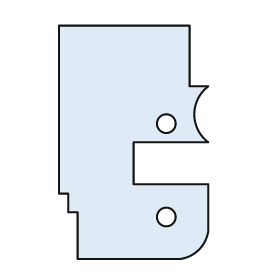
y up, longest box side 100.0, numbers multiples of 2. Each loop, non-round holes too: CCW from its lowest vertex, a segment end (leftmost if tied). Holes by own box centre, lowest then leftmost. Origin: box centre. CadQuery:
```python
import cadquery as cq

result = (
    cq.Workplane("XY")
    .moveTo(-24.0, -50.0)
    .lineTo(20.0, -50.0)
    .threePointArc((28.0, -46.0), (32.0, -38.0))
    .lineTo(32.0, -18.0)
    .lineTo(0.0, -18.0)
    .lineTo(0.0, 0.0)
    .lineTo(32.0, 0.0)
    .threePointArc((26.0, 12.0), (32.0, 24.0))
    .lineTo(24.0, 24.0)
    .lineTo(24.0, 50.0)
    .lineTo(-32.0, 50.0)
    .lineTo(-32.0, -22.0)
    .lineTo(-28.0, -22.0)
    .lineTo(-28.0, -30.0)
    .lineTo(-24.0, -30.0)
    .close()
    .moveTo(14.0, -32.0)
    .circle(4.0)
    .moveTo(14.0, 8.0)
    .circle(4.0)
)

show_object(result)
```